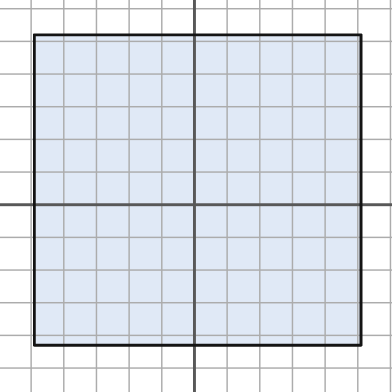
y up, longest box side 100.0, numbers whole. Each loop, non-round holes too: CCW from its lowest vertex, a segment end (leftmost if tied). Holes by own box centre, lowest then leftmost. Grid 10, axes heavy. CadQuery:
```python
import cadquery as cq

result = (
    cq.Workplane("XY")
    .moveTo(-49.0, -43.0)
    .lineTo(51.0, -43.0)
    .lineTo(51.0, 52.0)
    .lineTo(-49.0, 52.0)
    .close()
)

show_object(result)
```